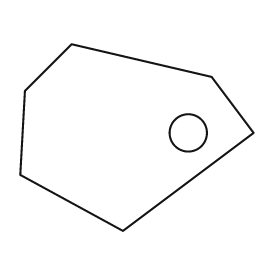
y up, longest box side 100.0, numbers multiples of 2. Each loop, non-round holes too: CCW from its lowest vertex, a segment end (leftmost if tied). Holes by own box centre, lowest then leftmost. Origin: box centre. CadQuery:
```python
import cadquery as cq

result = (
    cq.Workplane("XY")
    .moveTo(-6.0, -40.0)
    .lineTo(50.0, 2.0)
    .lineTo(32.0, 26.0)
    .lineTo(-28.0, 40.0)
    .lineTo(-48.0, 20.0)
    .lineTo(-50.0, -16.0)
    .close()
    .moveTo(22.0, 2.0)
    .circle(8.0)
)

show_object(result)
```